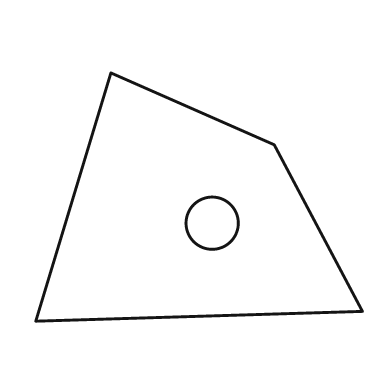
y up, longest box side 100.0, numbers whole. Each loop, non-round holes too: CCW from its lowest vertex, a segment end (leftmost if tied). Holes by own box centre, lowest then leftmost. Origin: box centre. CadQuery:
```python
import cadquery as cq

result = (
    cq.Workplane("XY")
    .moveTo(-50.0, -38.0)
    .lineTo(50.0, -35.0)
    .lineTo(23.0, 16.0)
    .lineTo(-27.0, 38.0)
    .close()
    .moveTo(4.0, -8.0)
    .circle(8.0)
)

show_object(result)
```